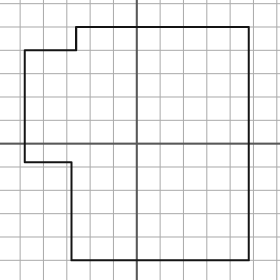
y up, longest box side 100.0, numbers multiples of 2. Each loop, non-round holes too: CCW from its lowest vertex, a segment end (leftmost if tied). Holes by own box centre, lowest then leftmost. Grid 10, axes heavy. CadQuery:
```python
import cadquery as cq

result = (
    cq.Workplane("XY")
    .moveTo(-28.0, -50.0)
    .lineTo(48.0, -50.0)
    .lineTo(48.0, 50.0)
    .lineTo(-26.0, 50.0)
    .lineTo(-26.0, 40.0)
    .lineTo(-48.0, 40.0)
    .lineTo(-48.0, -8.0)
    .lineTo(-28.0, -8.0)
    .close()
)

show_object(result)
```